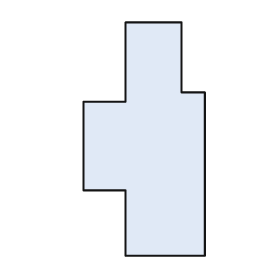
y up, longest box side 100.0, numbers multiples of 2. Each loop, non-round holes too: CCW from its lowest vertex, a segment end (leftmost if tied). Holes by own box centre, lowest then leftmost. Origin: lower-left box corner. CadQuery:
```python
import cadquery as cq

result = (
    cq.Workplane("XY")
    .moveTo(18.0, 0.0)
    .lineTo(52.0, 0.0)
    .lineTo(52.0, 70.0)
    .lineTo(42.0, 70.0)
    .lineTo(42.0, 100.0)
    .lineTo(18.0, 100.0)
    .lineTo(18.0, 66.0)
    .lineTo(0.0, 66.0)
    .lineTo(0.0, 28.0)
    .lineTo(18.0, 28.0)
    .close()
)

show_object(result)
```